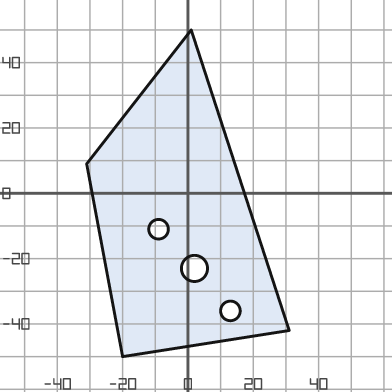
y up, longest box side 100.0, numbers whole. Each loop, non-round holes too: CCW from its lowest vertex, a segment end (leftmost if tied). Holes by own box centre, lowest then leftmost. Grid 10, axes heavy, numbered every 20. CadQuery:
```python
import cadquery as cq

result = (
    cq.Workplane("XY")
    .moveTo(-20.0, -50.0)
    .lineTo(31.0, -42.0)
    .lineTo(1.0, 50.0)
    .lineTo(-31.0, 9.0)
    .close()
    .moveTo(13.0, -36.0)
    .circle(3.0)
    .moveTo(2.0, -23.0)
    .circle(4.0)
    .moveTo(-9.0, -11.0)
    .circle(3.0)
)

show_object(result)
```